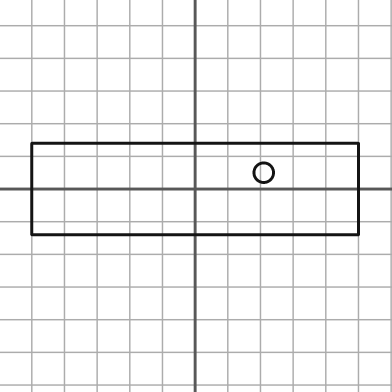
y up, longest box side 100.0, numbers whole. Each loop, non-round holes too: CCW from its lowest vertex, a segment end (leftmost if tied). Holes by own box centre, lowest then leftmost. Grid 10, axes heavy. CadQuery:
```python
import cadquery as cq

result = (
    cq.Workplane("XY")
    .moveTo(-50.0, -14.0)
    .lineTo(50.0, -14.0)
    .lineTo(50.0, 14.0)
    .lineTo(-50.0, 14.0)
    .close()
    .moveTo(21.0, 5.0)
    .circle(3.0)
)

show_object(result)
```